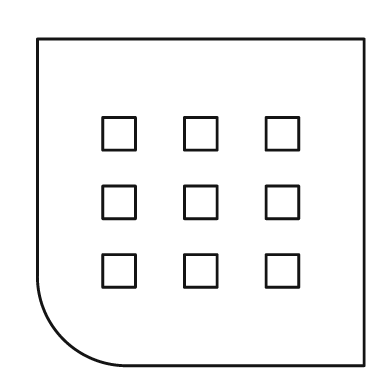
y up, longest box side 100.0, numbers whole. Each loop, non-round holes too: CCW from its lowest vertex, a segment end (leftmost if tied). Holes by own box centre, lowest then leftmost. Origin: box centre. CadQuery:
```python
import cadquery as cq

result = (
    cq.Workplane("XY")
    .moveTo(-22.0, -50.0)
    .lineTo(50.0, -50.0)
    .lineTo(50.0, 50.0)
    .lineTo(-50.0, 50.0)
    .lineTo(-50.0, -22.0)
    .threePointArc((-42.0, -42.0), (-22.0, -50.0))
    .close()
    .moveTo(-30.0, -26.0)
    .lineTo(-20.0, -26.0)
    .lineTo(-20.0, -16.0)
    .lineTo(-30.0, -16.0)
    .close()
    .moveTo(-5.0, -26.0)
    .lineTo(5.0, -26.0)
    .lineTo(5.0, -16.0)
    .lineTo(-5.0, -16.0)
    .close()
    .moveTo(20.0, -26.0)
    .lineTo(30.0, -26.0)
    .lineTo(30.0, -16.0)
    .lineTo(20.0, -16.0)
    .close()
    .moveTo(-30.0, -5.0)
    .lineTo(-20.0, -5.0)
    .lineTo(-20.0, 5.0)
    .lineTo(-30.0, 5.0)
    .close()
    .moveTo(-5.0, -5.0)
    .lineTo(5.0, -5.0)
    .lineTo(5.0, 5.0)
    .lineTo(-5.0, 5.0)
    .close()
    .moveTo(20.0, -5.0)
    .lineTo(30.0, -5.0)
    .lineTo(30.0, 5.0)
    .lineTo(20.0, 5.0)
    .close()
    .moveTo(-30.0, 16.0)
    .lineTo(-20.0, 16.0)
    .lineTo(-20.0, 26.0)
    .lineTo(-30.0, 26.0)
    .close()
    .moveTo(-5.0, 16.0)
    .lineTo(5.0, 16.0)
    .lineTo(5.0, 26.0)
    .lineTo(-5.0, 26.0)
    .close()
    .moveTo(20.0, 16.0)
    .lineTo(30.0, 16.0)
    .lineTo(30.0, 26.0)
    .lineTo(20.0, 26.0)
    .close()
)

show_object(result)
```